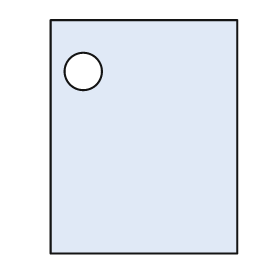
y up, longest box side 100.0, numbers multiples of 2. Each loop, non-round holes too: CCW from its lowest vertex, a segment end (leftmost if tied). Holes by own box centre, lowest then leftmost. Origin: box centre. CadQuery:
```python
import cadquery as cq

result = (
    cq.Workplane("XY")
    .moveTo(-40.0, -50.0)
    .lineTo(40.0, -50.0)
    .lineTo(40.0, 50.0)
    .lineTo(-40.0, 50.0)
    .close()
    .moveTo(-26.0, 28.0)
    .circle(8.0)
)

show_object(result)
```